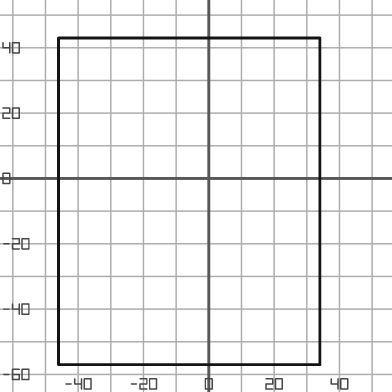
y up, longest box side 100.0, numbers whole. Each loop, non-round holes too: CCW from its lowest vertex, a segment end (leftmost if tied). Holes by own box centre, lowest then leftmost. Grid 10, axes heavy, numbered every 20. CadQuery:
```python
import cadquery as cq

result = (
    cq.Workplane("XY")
    .moveTo(-46.0, -57.0)
    .lineTo(34.0, -57.0)
    .lineTo(34.0, 43.0)
    .lineTo(-46.0, 43.0)
    .close()
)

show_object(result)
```